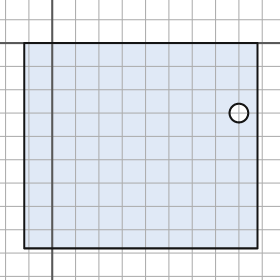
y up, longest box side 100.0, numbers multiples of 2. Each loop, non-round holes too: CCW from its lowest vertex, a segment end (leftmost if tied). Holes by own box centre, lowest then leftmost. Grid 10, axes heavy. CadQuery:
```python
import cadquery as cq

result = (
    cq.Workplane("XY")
    .moveTo(-12.0, -88.0)
    .lineTo(88.0, -88.0)
    .lineTo(88.0, 0.0)
    .lineTo(-12.0, 0.0)
    .close()
    .moveTo(80.0, -30.0)
    .circle(4.0)
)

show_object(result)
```